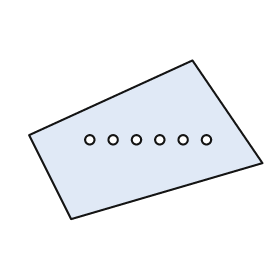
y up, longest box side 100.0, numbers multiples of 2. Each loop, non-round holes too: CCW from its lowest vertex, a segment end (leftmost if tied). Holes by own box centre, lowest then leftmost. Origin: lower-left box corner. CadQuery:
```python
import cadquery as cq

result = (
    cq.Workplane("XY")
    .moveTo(18.0, 0.0)
    .lineTo(100.0, 24.0)
    .lineTo(70.0, 68.0)
    .lineTo(0.0, 36.0)
    .close()
    .moveTo(26.0, 34.0)
    .circle(2.0)
    .moveTo(36.0, 34.0)
    .circle(2.0)
    .moveTo(46.0, 34.0)
    .circle(2.0)
    .moveTo(56.0, 34.0)
    .circle(2.0)
    .moveTo(66.0, 34.0)
    .circle(2.0)
    .moveTo(76.0, 34.0)
    .circle(2.0)
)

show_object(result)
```